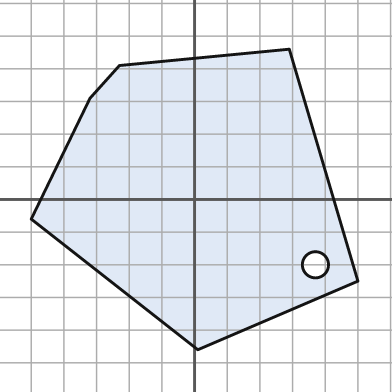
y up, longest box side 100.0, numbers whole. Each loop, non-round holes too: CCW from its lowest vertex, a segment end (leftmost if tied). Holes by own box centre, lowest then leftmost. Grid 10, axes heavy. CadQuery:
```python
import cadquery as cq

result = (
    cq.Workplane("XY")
    .moveTo(1.0, -46.0)
    .lineTo(50.0, -25.0)
    .lineTo(29.0, 46.0)
    .lineTo(-23.0, 41.0)
    .lineTo(-32.0, 31.0)
    .lineTo(-50.0, -6.0)
    .close()
    .moveTo(37.0, -20.0)
    .circle(4.0)
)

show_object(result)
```